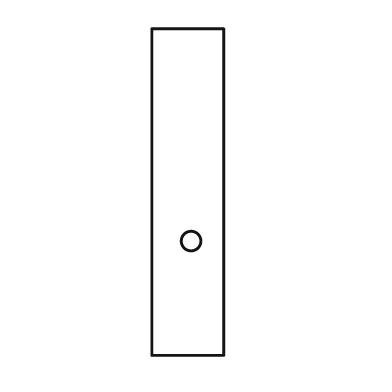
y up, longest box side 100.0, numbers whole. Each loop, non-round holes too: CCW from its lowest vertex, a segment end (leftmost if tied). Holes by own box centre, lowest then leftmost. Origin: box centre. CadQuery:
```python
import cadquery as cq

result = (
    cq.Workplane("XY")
    .moveTo(-11.0, -50.0)
    .lineTo(11.0, -50.0)
    .lineTo(11.0, 50.0)
    .lineTo(-11.0, 50.0)
    .close()
    .moveTo(1.0, -15.0)
    .circle(3.0)
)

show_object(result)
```